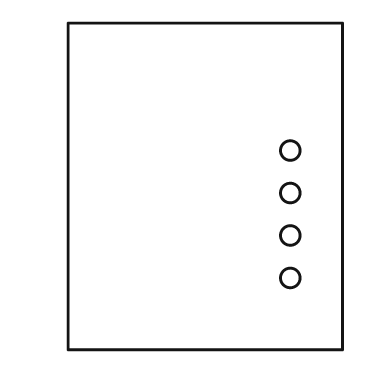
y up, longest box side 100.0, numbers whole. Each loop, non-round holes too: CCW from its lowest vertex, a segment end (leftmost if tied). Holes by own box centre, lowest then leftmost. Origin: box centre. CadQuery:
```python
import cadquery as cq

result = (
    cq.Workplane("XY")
    .moveTo(-42.0, -50.0)
    .lineTo(42.0, -50.0)
    .lineTo(42.0, 50.0)
    .lineTo(-42.0, 50.0)
    .close()
    .moveTo(26.0, -28.0)
    .circle(3.0)
    .moveTo(26.0, -15.0)
    .circle(3.0)
    .moveTo(26.0, -2.0)
    .circle(3.0)
    .moveTo(26.0, 11.0)
    .circle(3.0)
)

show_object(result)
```